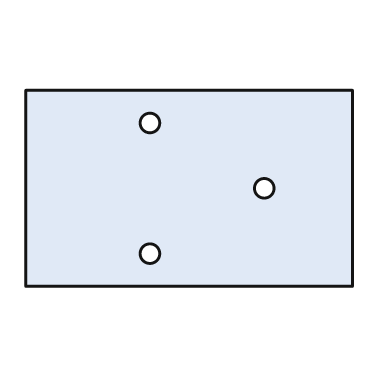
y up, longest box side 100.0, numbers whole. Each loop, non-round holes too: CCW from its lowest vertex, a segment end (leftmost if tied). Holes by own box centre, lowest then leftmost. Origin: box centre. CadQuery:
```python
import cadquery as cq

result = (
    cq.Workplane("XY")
    .moveTo(-50.0, -30.0)
    .lineTo(50.0, -30.0)
    .lineTo(50.0, 30.0)
    .lineTo(-50.0, 30.0)
    .close()
    .moveTo(-12.0, -20.0)
    .circle(3.0)
    .moveTo(23.0, 0.0)
    .circle(3.0)
    .moveTo(-12.0, 20.0)
    .circle(3.0)
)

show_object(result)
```